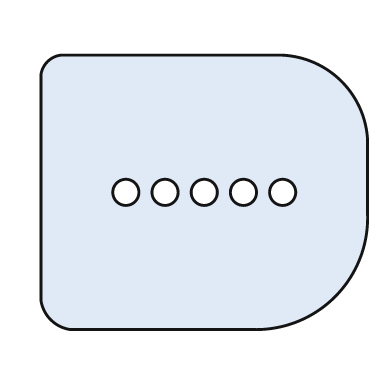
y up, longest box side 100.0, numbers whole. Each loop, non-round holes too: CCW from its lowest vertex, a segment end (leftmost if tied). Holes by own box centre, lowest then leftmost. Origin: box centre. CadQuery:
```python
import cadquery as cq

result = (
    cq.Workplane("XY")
    .moveTo(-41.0, -42.0)
    .lineTo(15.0, -42.0)
    .threePointArc((40.0, -32.0), (50.0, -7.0))
    .lineTo(50.0, 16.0)
    .threePointArc((42.0, 34.0), (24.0, 42.0))
    .lineTo(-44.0, 42.0)
    .threePointArc((-48.0, 40.0), (-50.0, 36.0))
    .lineTo(-50.0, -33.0)
    .threePointArc((-47.0, -39.0), (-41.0, -42.0))
    .close()
    .moveTo(-24.0, 0.0)
    .circle(4.0)
    .moveTo(-12.0, 0.0)
    .circle(4.0)
    .moveTo(0.0, 0.0)
    .circle(4.0)
    .moveTo(12.0, 0.0)
    .circle(4.0)
    .moveTo(24.0, 0.0)
    .circle(4.0)
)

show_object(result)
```